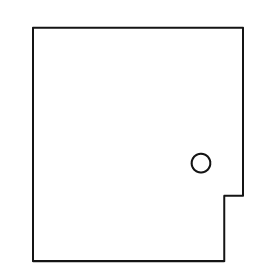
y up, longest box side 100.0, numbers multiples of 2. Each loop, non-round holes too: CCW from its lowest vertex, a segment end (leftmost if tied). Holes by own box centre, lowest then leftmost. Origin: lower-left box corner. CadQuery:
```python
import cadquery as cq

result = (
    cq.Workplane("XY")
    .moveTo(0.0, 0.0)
    .lineTo(82.0, 0.0)
    .lineTo(82.0, 28.0)
    .lineTo(90.0, 28.0)
    .lineTo(90.0, 100.0)
    .lineTo(0.0, 100.0)
    .close()
    .moveTo(72.0, 42.0)
    .circle(4.0)
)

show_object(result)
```